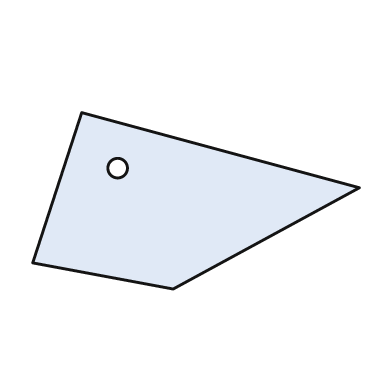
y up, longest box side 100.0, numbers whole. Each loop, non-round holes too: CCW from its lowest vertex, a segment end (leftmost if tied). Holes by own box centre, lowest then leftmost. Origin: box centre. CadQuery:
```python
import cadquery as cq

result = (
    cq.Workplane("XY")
    .moveTo(-7.0, -27.0)
    .lineTo(50.0, 4.0)
    .lineTo(-35.0, 27.0)
    .lineTo(-50.0, -19.0)
    .close()
    .moveTo(-24.0, 10.0)
    .circle(3.0)
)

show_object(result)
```